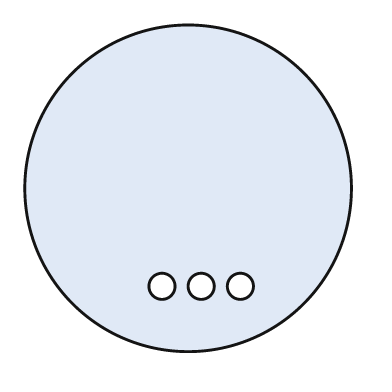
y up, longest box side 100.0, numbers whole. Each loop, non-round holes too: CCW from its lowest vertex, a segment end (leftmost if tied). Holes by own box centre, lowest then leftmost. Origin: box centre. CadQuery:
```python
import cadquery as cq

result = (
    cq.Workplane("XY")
    .moveTo(0.0, 0.0)
    .circle(50.0)
    .moveTo(-8.0, -30.0)
    .circle(4.0)
    .moveTo(4.0, -30.0)
    .circle(4.0)
    .moveTo(16.0, -30.0)
    .circle(4.0)
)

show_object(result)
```